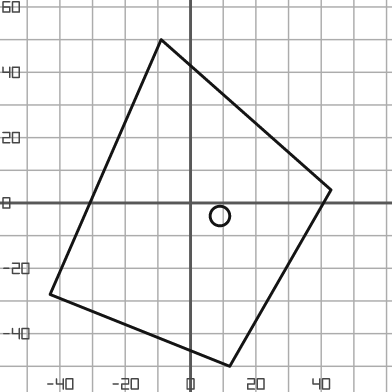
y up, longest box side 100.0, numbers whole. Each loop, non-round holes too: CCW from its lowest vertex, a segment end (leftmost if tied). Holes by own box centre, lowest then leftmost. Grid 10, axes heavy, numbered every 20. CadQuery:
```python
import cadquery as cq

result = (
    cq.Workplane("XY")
    .moveTo(12.0, -50.0)
    .lineTo(43.0, 4.0)
    .lineTo(-9.0, 50.0)
    .lineTo(-43.0, -28.0)
    .close()
    .moveTo(9.0, -4.0)
    .circle(3.0)
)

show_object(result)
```